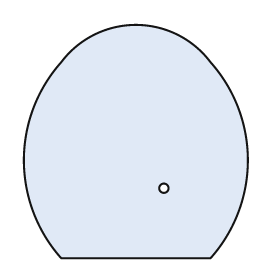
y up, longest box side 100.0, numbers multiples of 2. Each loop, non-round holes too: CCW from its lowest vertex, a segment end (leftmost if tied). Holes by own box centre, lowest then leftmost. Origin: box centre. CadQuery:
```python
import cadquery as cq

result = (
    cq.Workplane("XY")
    .moveTo(-32.0, -50.0)
    .lineTo(32.0, -50.0)
    .threePointArc((48.0, -8.0), (32.0, 34.0))
    .threePointArc((0.0, 50.0), (-32.0, 34.0))
    .threePointArc((-48.0, -8.0), (-32.0, -50.0))
    .close()
    .moveTo(12.0, -20.0)
    .circle(2.0)
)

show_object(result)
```